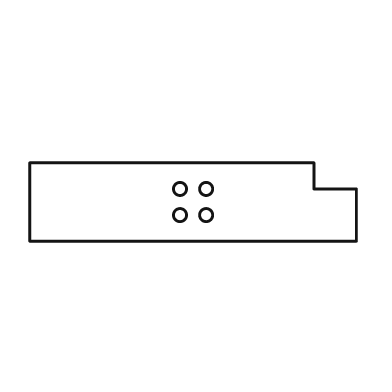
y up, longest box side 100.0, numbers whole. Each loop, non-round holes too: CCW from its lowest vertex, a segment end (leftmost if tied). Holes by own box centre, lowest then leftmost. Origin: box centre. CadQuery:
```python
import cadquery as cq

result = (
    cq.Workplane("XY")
    .moveTo(-50.0, -12.0)
    .lineTo(50.0, -12.0)
    .lineTo(50.0, 4.0)
    .lineTo(37.0, 4.0)
    .lineTo(37.0, 12.0)
    .lineTo(-50.0, 12.0)
    .close()
    .moveTo(-4.0, -4.0)
    .circle(2.0)
    .moveTo(4.0, -4.0)
    .circle(2.0)
    .moveTo(-4.0, 4.0)
    .circle(2.0)
    .moveTo(4.0, 4.0)
    .circle(2.0)
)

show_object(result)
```